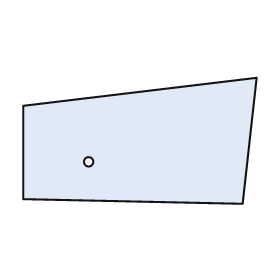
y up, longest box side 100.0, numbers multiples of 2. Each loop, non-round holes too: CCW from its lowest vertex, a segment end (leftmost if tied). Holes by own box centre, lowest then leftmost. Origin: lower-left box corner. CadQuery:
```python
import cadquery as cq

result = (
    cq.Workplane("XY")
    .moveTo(94.0, 0.0)
    .lineTo(100.0, 54.0)
    .lineTo(0.0, 42.0)
    .lineTo(0.0, 2.0)
    .close()
    .moveTo(28.0, 18.0)
    .circle(2.0)
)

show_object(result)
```